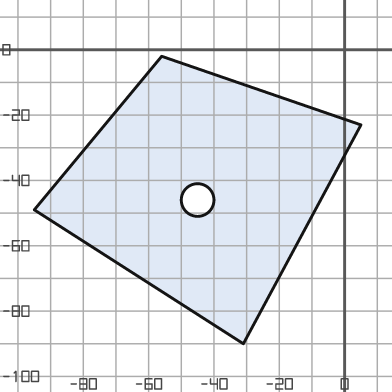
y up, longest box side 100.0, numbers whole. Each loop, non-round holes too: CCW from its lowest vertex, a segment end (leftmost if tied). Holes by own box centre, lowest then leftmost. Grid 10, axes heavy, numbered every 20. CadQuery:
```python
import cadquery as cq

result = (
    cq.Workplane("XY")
    .moveTo(-31.0, -90.0)
    .lineTo(5.0, -23.0)
    .lineTo(-56.0, -2.0)
    .lineTo(-95.0, -49.0)
    .close()
    .moveTo(-45.0, -46.0)
    .circle(5.0)
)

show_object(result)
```